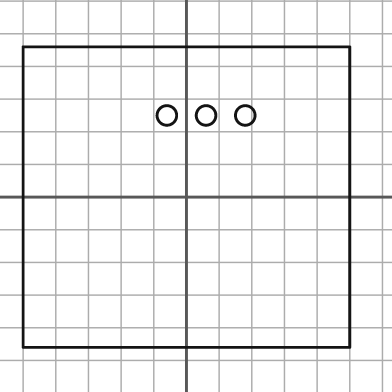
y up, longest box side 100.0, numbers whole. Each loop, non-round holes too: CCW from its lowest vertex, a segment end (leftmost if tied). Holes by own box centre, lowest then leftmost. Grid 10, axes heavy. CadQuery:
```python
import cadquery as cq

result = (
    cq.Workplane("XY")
    .moveTo(-50.0, -46.0)
    .lineTo(50.0, -46.0)
    .lineTo(50.0, 46.0)
    .lineTo(-50.0, 46.0)
    .close()
    .moveTo(-6.0, 25.0)
    .circle(3.0)
    .moveTo(6.0, 25.0)
    .circle(3.0)
    .moveTo(18.0, 25.0)
    .circle(3.0)
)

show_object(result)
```